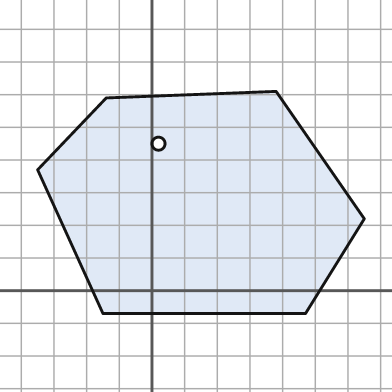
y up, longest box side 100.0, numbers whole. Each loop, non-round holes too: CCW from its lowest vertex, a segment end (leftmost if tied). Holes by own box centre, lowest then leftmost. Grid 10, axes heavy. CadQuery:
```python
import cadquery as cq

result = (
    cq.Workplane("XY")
    .moveTo(-15.0, -7.0)
    .lineTo(47.0, -7.0)
    .lineTo(65.0, 22.0)
    .lineTo(38.0, 61.0)
    .lineTo(-14.0, 59.0)
    .lineTo(-35.0, 37.0)
    .close()
    .moveTo(2.0, 45.0)
    .circle(2.0)
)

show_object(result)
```